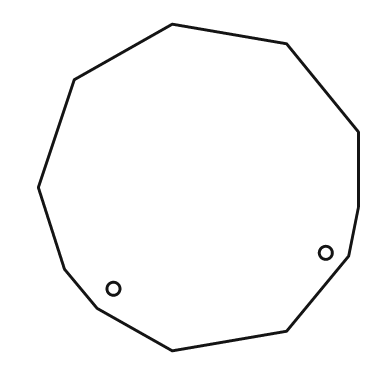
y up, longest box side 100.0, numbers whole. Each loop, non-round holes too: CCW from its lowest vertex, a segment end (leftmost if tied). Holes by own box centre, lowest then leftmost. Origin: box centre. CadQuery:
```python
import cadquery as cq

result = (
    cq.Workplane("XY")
    .moveTo(-8.0, -50.0)
    .lineTo(27.0, -44.0)
    .lineTo(46.0, -21.0)
    .lineTo(49.0, -6.0)
    .lineTo(49.0, 17.0)
    .lineTo(27.0, 44.0)
    .lineTo(-8.0, 50.0)
    .lineTo(-38.0, 33.0)
    .lineTo(-49.0, 0.0)
    .lineTo(-41.0, -25.0)
    .lineTo(-31.0, -37.0)
    .close()
    .moveTo(-26.0, -31.0)
    .circle(2.0)
    .moveTo(39.0, -20.0)
    .circle(2.0)
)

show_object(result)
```